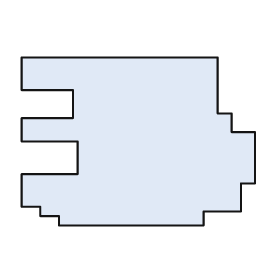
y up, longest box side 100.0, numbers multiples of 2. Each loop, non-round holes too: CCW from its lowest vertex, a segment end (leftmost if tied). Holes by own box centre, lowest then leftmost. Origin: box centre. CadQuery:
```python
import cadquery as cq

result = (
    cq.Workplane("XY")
    .moveTo(-34.0, -36.0)
    .lineTo(28.0, -36.0)
    .lineTo(28.0, -30.0)
    .lineTo(44.0, -30.0)
    .lineTo(44.0, -18.0)
    .lineTo(50.0, -18.0)
    .lineTo(50.0, 4.0)
    .lineTo(40.0, 4.0)
    .lineTo(40.0, 12.0)
    .lineTo(34.0, 12.0)
    .lineTo(34.0, 36.0)
    .lineTo(-50.0, 36.0)
    .lineTo(-50.0, 22.0)
    .lineTo(-28.0, 22.0)
    .lineTo(-28.0, 10.0)
    .lineTo(-50.0, 10.0)
    .lineTo(-50.0, 0.0)
    .lineTo(-26.0, 0.0)
    .lineTo(-26.0, -14.0)
    .lineTo(-50.0, -14.0)
    .lineTo(-50.0, -28.0)
    .lineTo(-42.0, -28.0)
    .lineTo(-42.0, -32.0)
    .lineTo(-34.0, -32.0)
    .close()
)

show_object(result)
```